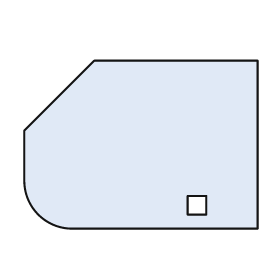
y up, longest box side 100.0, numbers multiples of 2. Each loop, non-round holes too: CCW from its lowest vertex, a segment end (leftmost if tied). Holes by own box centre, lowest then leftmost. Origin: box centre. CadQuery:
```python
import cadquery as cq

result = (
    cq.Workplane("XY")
    .moveTo(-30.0, -36.0)
    .lineTo(50.0, -36.0)
    .lineTo(50.0, 36.0)
    .lineTo(-20.0, 36.0)
    .lineTo(-50.0, 6.0)
    .lineTo(-50.0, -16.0)
    .threePointArc((-44.0, -30.0), (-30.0, -36.0))
    .close()
    .moveTo(20.0, -30.0)
    .lineTo(28.0, -30.0)
    .lineTo(28.0, -22.0)
    .lineTo(20.0, -22.0)
    .close()
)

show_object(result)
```